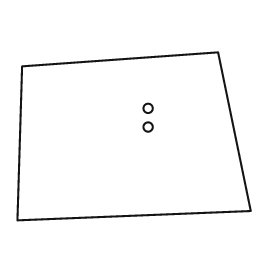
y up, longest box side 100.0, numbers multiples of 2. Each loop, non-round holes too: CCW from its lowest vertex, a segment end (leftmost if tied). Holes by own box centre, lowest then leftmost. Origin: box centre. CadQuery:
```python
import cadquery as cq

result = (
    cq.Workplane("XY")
    .moveTo(-50.0, -36.0)
    .lineTo(50.0, -32.0)
    .lineTo(36.0, 36.0)
    .lineTo(-48.0, 30.0)
    .close()
    .moveTo(6.0, 4.0)
    .circle(2.0)
    .moveTo(6.0, 12.0)
    .circle(2.0)
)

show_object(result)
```